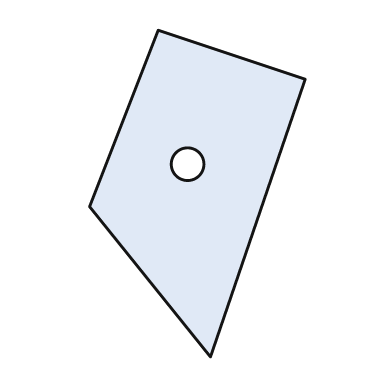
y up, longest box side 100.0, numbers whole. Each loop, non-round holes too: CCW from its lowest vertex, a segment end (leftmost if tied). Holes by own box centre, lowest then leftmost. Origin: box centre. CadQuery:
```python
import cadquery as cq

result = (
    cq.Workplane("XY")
    .moveTo(4.0, -50.0)
    .lineTo(33.0, 35.0)
    .lineTo(-12.0, 50.0)
    .lineTo(-33.0, -4.0)
    .close()
    .moveTo(-3.0, 9.0)
    .circle(5.0)
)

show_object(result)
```